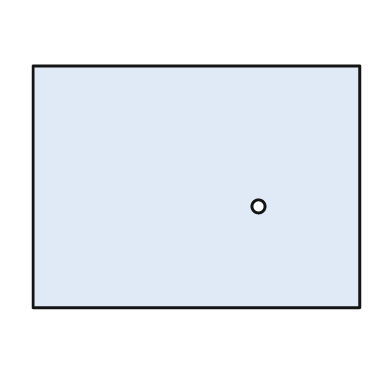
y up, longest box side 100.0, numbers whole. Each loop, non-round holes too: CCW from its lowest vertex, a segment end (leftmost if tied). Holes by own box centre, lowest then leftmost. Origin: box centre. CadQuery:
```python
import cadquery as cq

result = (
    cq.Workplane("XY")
    .moveTo(-50.0, -37.0)
    .lineTo(50.0, -37.0)
    .lineTo(50.0, 37.0)
    .lineTo(-50.0, 37.0)
    .close()
    .moveTo(19.0, -6.0)
    .circle(2.0)
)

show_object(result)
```